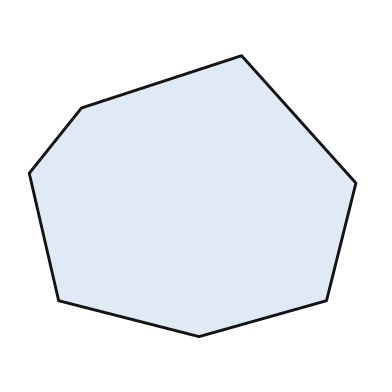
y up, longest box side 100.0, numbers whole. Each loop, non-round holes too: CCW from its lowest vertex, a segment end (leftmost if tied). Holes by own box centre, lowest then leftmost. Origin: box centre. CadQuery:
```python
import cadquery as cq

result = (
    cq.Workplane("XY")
    .moveTo(2.0, -43.0)
    .lineTo(41.0, -32.0)
    .lineTo(50.0, 4.0)
    .lineTo(15.0, 43.0)
    .lineTo(-34.0, 27.0)
    .lineTo(-50.0, 7.0)
    .lineTo(-41.0, -32.0)
    .close()
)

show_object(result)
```